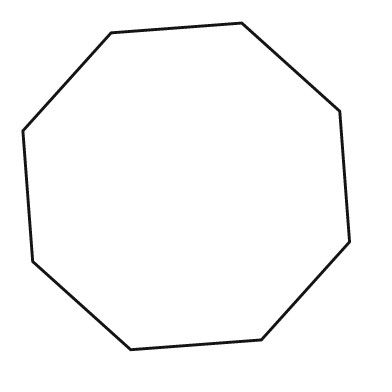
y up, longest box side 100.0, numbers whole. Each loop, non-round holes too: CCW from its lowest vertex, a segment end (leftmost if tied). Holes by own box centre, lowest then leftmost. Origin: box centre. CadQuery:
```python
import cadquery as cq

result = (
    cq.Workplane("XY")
    .moveTo(-17.0, -50.0)
    .lineTo(23.0, -47.0)
    .lineTo(50.0, -17.0)
    .lineTo(47.0, 23.0)
    .lineTo(17.0, 50.0)
    .lineTo(-23.0, 47.0)
    .lineTo(-50.0, 17.0)
    .lineTo(-47.0, -23.0)
    .close()
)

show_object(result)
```